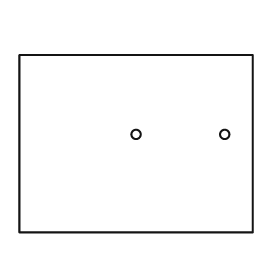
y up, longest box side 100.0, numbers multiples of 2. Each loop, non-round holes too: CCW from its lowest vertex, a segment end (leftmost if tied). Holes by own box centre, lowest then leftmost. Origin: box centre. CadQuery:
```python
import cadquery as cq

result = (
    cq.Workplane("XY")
    .moveTo(-50.0, -38.0)
    .lineTo(50.0, -38.0)
    .lineTo(50.0, 38.0)
    .lineTo(-50.0, 38.0)
    .close()
    .moveTo(0.0, 4.0)
    .circle(2.0)
    .moveTo(38.0, 4.0)
    .circle(2.0)
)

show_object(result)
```